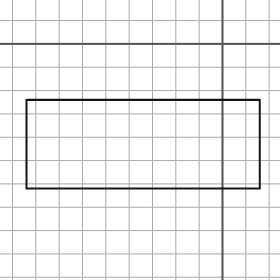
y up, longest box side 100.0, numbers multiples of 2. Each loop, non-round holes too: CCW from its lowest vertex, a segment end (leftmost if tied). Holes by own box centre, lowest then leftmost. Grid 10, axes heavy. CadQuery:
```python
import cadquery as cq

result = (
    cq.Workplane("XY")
    .moveTo(-84.0, -62.0)
    .lineTo(16.0, -62.0)
    .lineTo(16.0, -24.0)
    .lineTo(-84.0, -24.0)
    .close()
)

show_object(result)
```